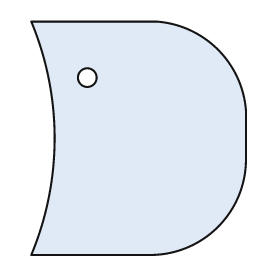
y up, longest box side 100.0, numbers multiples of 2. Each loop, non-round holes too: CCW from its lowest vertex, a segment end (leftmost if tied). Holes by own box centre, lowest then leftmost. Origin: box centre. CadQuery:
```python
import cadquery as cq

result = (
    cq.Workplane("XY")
    .moveTo(-46.0, -50.0)
    .lineTo(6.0, -50.0)
    .threePointArc((34.0, -38.0), (46.0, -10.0))
    .lineTo(46.0, 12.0)
    .threePointArc((34.0, 38.0), (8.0, 50.0))
    .lineTo(-46.0, 50.0)
    .threePointArc((-36.0, 0.0), (-46.0, -50.0))
    .close()
    .moveTo(-22.0, 26.0)
    .circle(4.0)
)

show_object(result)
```